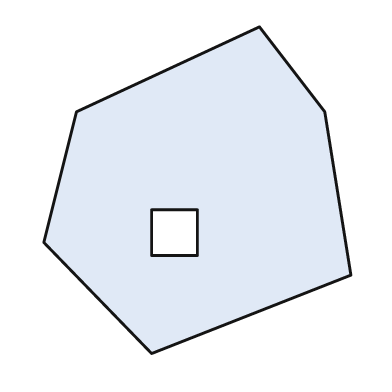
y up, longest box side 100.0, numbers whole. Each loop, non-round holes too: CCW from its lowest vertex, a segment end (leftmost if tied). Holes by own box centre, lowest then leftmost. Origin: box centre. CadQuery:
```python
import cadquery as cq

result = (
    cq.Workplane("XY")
    .moveTo(-14.0, -50.0)
    .lineTo(47.0, -26.0)
    .lineTo(39.0, 24.0)
    .lineTo(19.0, 50.0)
    .lineTo(-37.0, 24.0)
    .lineTo(-47.0, -16.0)
    .close()
    .moveTo(-14.0, -20.0)
    .lineTo(0.0, -20.0)
    .lineTo(0.0, -6.0)
    .lineTo(-14.0, -6.0)
    .close()
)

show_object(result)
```